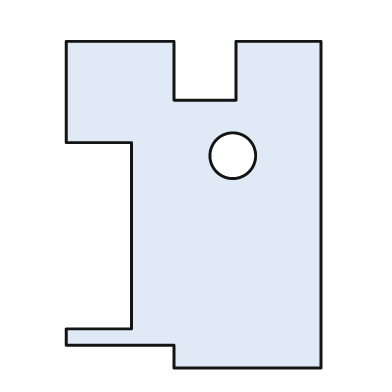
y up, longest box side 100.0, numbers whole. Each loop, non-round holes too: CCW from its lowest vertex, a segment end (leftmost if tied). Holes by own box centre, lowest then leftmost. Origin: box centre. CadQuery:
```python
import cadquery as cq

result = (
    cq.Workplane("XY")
    .moveTo(-6.0, -50.0)
    .lineTo(39.0, -50.0)
    .lineTo(39.0, 50.0)
    .lineTo(13.0, 50.0)
    .lineTo(13.0, 32.0)
    .lineTo(-6.0, 32.0)
    .lineTo(-6.0, 50.0)
    .lineTo(-39.0, 50.0)
    .lineTo(-39.0, 19.0)
    .lineTo(-19.0, 19.0)
    .lineTo(-19.0, -38.0)
    .lineTo(-39.0, -38.0)
    .lineTo(-39.0, -43.0)
    .lineTo(-6.0, -43.0)
    .close()
    .moveTo(12.0, 15.0)
    .circle(7.0)
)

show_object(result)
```